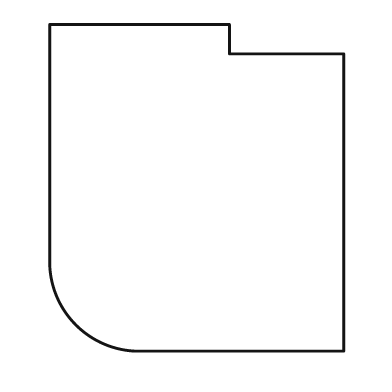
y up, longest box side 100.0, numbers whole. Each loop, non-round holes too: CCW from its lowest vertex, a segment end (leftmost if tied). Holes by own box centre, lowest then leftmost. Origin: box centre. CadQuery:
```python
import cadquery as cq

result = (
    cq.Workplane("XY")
    .moveTo(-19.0, -50.0)
    .lineTo(45.0, -50.0)
    .lineTo(45.0, 41.0)
    .lineTo(10.0, 41.0)
    .lineTo(10.0, 50.0)
    .lineTo(-45.0, 50.0)
    .lineTo(-45.0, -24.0)
    .threePointArc((-37.0, -42.0), (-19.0, -50.0))
    .close()
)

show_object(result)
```